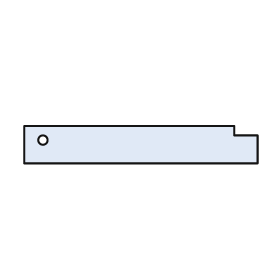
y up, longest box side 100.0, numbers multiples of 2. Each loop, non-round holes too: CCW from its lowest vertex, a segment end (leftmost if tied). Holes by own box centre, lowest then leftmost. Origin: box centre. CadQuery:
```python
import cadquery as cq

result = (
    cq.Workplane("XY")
    .moveTo(-50.0, -8.0)
    .lineTo(50.0, -8.0)
    .lineTo(50.0, 4.0)
    .lineTo(40.0, 4.0)
    .lineTo(40.0, 8.0)
    .lineTo(-50.0, 8.0)
    .close()
    .moveTo(-42.0, 2.0)
    .circle(2.0)
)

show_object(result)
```